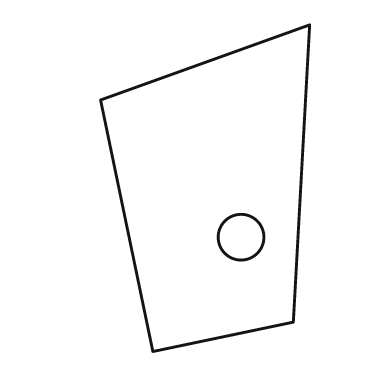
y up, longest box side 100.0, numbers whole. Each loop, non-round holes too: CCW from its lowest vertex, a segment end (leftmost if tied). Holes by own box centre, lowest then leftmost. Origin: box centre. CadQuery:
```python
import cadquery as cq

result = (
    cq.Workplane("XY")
    .moveTo(-16.0, -50.0)
    .lineTo(27.0, -41.0)
    .lineTo(32.0, 50.0)
    .lineTo(-32.0, 27.0)
    .close()
    .moveTo(11.0, -15.0)
    .circle(7.0)
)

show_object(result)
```